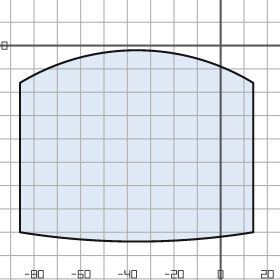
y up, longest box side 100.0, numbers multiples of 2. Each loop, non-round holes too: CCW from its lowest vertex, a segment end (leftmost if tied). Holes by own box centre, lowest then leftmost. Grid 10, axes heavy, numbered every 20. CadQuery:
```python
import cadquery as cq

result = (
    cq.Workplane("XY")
    .moveTo(-86.0, -80.0)
    .threePointArc((-36.0, -84.0), (14.0, -80.0))
    .lineTo(14.0, -16.0)
    .threePointArc((-36.0, -2.0), (-86.0, -16.0))
    .close()
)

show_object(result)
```